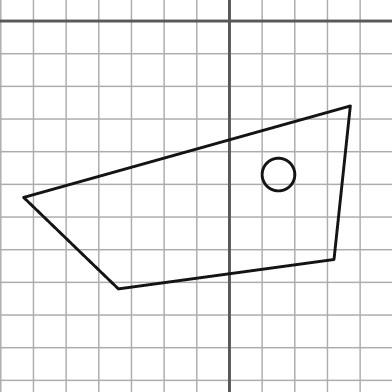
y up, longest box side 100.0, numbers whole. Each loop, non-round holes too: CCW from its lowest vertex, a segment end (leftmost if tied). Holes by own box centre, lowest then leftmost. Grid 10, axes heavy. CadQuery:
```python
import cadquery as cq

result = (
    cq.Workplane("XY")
    .moveTo(-34.0, -82.0)
    .lineTo(32.0, -73.0)
    .lineTo(37.0, -26.0)
    .lineTo(-63.0, -54.0)
    .close()
    .moveTo(15.0, -47.0)
    .circle(5.0)
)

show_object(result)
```